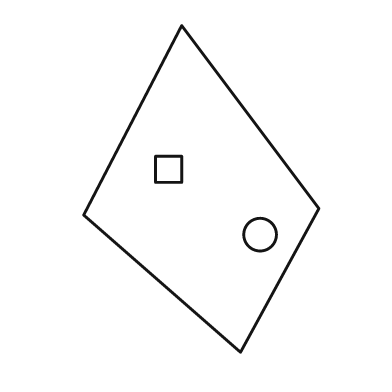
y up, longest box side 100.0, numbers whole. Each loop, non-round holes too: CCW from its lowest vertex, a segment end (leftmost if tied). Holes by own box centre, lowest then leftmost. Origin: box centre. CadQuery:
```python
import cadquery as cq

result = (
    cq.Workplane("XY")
    .moveTo(12.0, -50.0)
    .lineTo(36.0, -6.0)
    .lineTo(-6.0, 50.0)
    .lineTo(-36.0, -8.0)
    .close()
    .moveTo(18.0, -14.0)
    .circle(5.0)
    .moveTo(-14.0, 2.0)
    .lineTo(-6.0, 2.0)
    .lineTo(-6.0, 10.0)
    .lineTo(-14.0, 10.0)
    .close()
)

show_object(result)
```